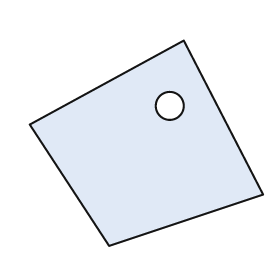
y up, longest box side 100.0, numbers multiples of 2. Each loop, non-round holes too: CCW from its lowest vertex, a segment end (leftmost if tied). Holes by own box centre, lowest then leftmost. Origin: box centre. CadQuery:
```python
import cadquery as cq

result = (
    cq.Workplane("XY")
    .moveTo(-16.0, -44.0)
    .lineTo(50.0, -22.0)
    .lineTo(16.0, 44.0)
    .lineTo(-50.0, 8.0)
    .close()
    .moveTo(10.0, 16.0)
    .circle(6.0)
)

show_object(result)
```